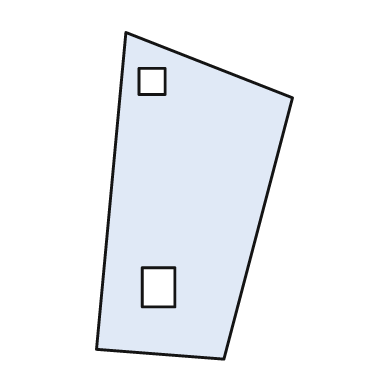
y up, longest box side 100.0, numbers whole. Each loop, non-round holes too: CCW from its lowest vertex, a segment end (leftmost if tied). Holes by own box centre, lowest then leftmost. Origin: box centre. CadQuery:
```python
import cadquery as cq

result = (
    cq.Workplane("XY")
    .moveTo(9.0, -50.0)
    .lineTo(30.0, 30.0)
    .lineTo(-21.0, 50.0)
    .lineTo(-30.0, -47.0)
    .close()
    .moveTo(-16.0, -34.0)
    .lineTo(-6.0, -34.0)
    .lineTo(-6.0, -22.0)
    .lineTo(-16.0, -22.0)
    .close()
    .moveTo(-17.0, 31.0)
    .lineTo(-9.0, 31.0)
    .lineTo(-9.0, 39.0)
    .lineTo(-17.0, 39.0)
    .close()
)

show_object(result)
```